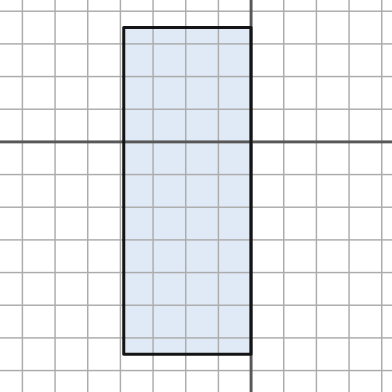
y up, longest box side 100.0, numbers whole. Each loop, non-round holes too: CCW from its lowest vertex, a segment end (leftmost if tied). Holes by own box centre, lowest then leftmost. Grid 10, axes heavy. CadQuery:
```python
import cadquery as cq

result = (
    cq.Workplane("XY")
    .moveTo(-39.0, -65.0)
    .lineTo(0.0, -65.0)
    .lineTo(0.0, 35.0)
    .lineTo(-39.0, 35.0)
    .close()
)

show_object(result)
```